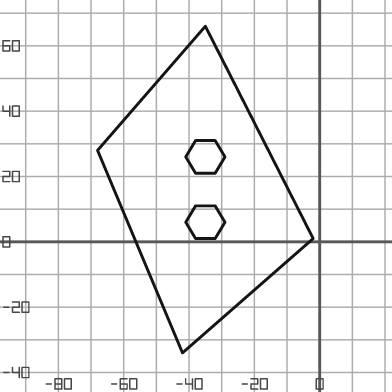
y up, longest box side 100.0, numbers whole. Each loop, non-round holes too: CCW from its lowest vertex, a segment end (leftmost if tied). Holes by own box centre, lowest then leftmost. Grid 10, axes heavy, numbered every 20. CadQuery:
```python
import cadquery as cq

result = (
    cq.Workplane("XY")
    .moveTo(-42.0, -34.0)
    .lineTo(-2.0, 1.0)
    .lineTo(-35.0, 66.0)
    .lineTo(-68.0, 28.0)
    .close()
    .moveTo(-38.0, 1.0)
    .lineTo(-32.0, 1.0)
    .lineTo(-29.0, 6.0)
    .lineTo(-32.0, 11.0)
    .lineTo(-38.0, 11.0)
    .lineTo(-41.0, 6.0)
    .close()
    .moveTo(-38.0, 21.0)
    .lineTo(-32.0, 21.0)
    .lineTo(-29.0, 26.0)
    .lineTo(-32.0, 31.0)
    .lineTo(-38.0, 31.0)
    .lineTo(-41.0, 26.0)
    .close()
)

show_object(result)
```